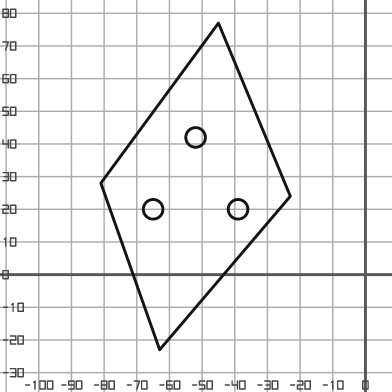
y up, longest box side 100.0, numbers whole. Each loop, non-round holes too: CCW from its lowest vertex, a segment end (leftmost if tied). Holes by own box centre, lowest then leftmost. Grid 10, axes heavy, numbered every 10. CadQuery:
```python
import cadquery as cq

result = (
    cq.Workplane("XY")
    .moveTo(-63.0, -23.0)
    .lineTo(-23.0, 24.0)
    .lineTo(-45.0, 77.0)
    .lineTo(-81.0, 28.0)
    .close()
    .moveTo(-65.0, 20.0)
    .circle(3.0)
    .moveTo(-39.0, 20.0)
    .circle(3.0)
    .moveTo(-52.0, 42.0)
    .circle(3.0)
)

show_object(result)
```